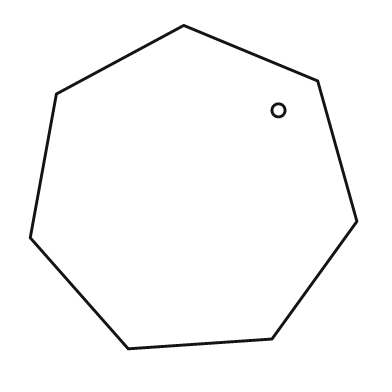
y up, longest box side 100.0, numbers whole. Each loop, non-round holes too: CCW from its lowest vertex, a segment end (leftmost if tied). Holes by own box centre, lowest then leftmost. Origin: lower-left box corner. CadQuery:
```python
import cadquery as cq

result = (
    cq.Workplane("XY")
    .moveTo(30.0, 0.0)
    .lineTo(74.0, 3.0)
    .lineTo(100.0, 39.0)
    .lineTo(88.0, 82.0)
    .lineTo(47.0, 99.0)
    .lineTo(8.0, 78.0)
    .lineTo(0.0, 34.0)
    .close()
    .moveTo(76.0, 73.0)
    .circle(2.0)
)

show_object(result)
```